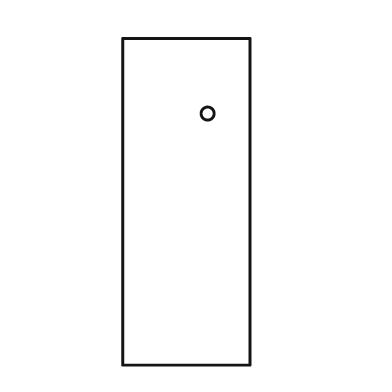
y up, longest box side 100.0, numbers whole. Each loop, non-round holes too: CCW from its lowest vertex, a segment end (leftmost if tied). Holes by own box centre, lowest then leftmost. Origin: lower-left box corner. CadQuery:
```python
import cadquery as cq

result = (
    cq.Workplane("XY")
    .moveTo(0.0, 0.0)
    .lineTo(39.0, 0.0)
    .lineTo(39.0, 100.0)
    .lineTo(0.0, 100.0)
    .close()
    .moveTo(26.0, 77.0)
    .circle(2.0)
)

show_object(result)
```